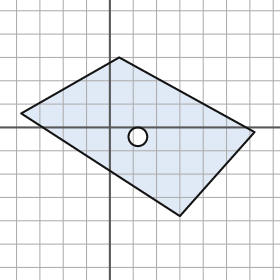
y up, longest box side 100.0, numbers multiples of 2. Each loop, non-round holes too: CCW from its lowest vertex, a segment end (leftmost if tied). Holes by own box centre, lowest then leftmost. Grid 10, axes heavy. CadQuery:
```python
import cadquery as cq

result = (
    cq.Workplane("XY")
    .moveTo(30.0, -38.0)
    .lineTo(62.0, -2.0)
    .lineTo(4.0, 30.0)
    .lineTo(-38.0, 6.0)
    .close()
    .moveTo(12.0, -4.0)
    .circle(4.0)
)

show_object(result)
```